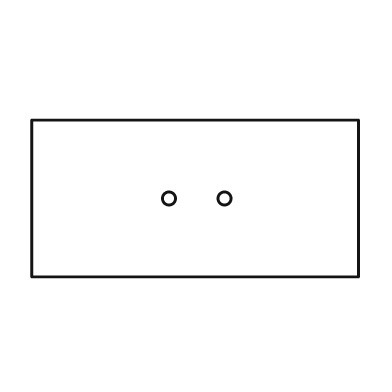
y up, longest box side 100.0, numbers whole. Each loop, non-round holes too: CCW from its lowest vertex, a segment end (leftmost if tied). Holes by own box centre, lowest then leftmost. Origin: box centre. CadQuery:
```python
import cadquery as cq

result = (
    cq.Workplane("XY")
    .moveTo(-50.0, -24.0)
    .lineTo(50.0, -24.0)
    .lineTo(50.0, 24.0)
    .lineTo(-50.0, 24.0)
    .close()
    .moveTo(-8.0, 0.0)
    .circle(2.0)
    .moveTo(9.0, 0.0)
    .circle(2.0)
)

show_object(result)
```